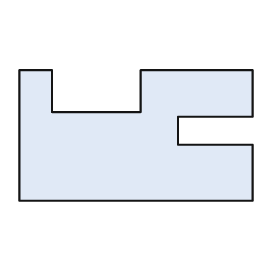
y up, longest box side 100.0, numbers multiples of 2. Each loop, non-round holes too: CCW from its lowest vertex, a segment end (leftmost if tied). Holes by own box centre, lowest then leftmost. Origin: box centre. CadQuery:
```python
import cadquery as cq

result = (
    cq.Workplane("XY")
    .moveTo(-50.0, -28.0)
    .lineTo(50.0, -28.0)
    .lineTo(50.0, -4.0)
    .lineTo(18.0, -4.0)
    .lineTo(18.0, 8.0)
    .lineTo(50.0, 8.0)
    .lineTo(50.0, 28.0)
    .lineTo(2.0, 28.0)
    .lineTo(2.0, 10.0)
    .lineTo(-36.0, 10.0)
    .lineTo(-36.0, 28.0)
    .lineTo(-50.0, 28.0)
    .close()
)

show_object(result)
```